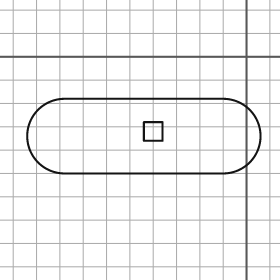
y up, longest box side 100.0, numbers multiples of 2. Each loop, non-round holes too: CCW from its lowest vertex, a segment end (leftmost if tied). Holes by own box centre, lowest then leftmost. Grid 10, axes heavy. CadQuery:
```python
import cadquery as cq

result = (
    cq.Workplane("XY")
    .moveTo(-78.0, -50.0)
    .lineTo(-10.0, -50.0)
    .threePointArc((6.0, -34.0), (-10.0, -18.0))
    .lineTo(-78.0, -18.0)
    .threePointArc((-94.0, -34.0), (-78.0, -50.0))
    .close()
    .moveTo(-44.0, -36.0)
    .lineTo(-36.0, -36.0)
    .lineTo(-36.0, -28.0)
    .lineTo(-44.0, -28.0)
    .close()
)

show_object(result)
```